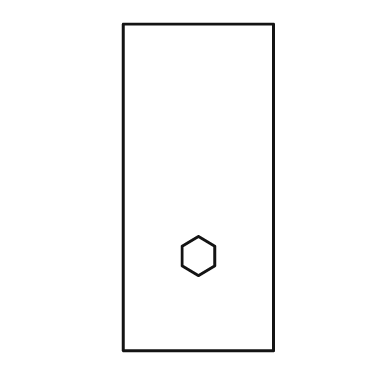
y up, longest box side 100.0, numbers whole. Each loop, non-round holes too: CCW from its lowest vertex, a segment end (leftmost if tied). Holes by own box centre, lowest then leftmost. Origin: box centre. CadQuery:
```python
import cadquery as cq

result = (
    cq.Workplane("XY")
    .moveTo(-23.0, -50.0)
    .lineTo(23.0, -50.0)
    .lineTo(23.0, 50.0)
    .lineTo(-23.0, 50.0)
    .close()
    .moveTo(0.0, -27.0)
    .lineTo(5.0, -24.0)
    .lineTo(5.0, -18.0)
    .lineTo(0.0, -15.0)
    .lineTo(-5.0, -18.0)
    .lineTo(-5.0, -24.0)
    .close()
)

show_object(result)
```